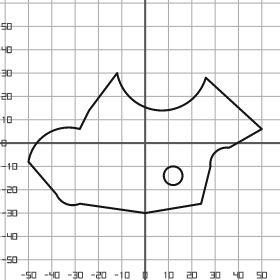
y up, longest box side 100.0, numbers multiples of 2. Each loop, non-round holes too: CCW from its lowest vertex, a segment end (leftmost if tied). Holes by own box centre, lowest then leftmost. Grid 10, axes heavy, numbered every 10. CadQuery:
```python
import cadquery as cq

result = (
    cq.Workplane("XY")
    .moveTo(0.0, -30.0)
    .lineTo(24.0, -26.0)
    .lineTo(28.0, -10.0)
    .threePointArc((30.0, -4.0), (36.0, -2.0))
    .lineTo(50.0, 6.0)
    .lineTo(26.0, 28.0)
    .threePointArc((6.0, 14.0), (-12.0, 30.0))
    .lineTo(-24.0, 14.0)
    .lineTo(-28.0, 6.0)
    .threePointArc((-42.0, 4.0), (-50.0, -8.0))
    .lineTo(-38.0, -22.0)
    .threePointArc((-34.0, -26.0), (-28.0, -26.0))
    .close()
    .moveTo(12.0, -14.0)
    .circle(4.0)
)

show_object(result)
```